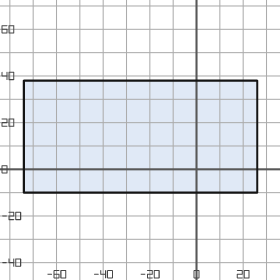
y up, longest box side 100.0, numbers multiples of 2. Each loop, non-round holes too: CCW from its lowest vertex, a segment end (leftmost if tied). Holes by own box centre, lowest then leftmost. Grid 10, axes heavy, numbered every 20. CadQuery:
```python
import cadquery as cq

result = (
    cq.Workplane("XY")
    .moveTo(-74.0, -10.0)
    .lineTo(26.0, -10.0)
    .lineTo(26.0, 38.0)
    .lineTo(-74.0, 38.0)
    .close()
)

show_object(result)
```